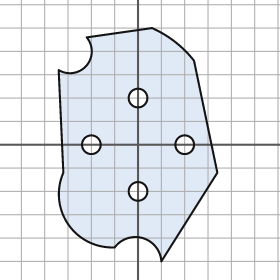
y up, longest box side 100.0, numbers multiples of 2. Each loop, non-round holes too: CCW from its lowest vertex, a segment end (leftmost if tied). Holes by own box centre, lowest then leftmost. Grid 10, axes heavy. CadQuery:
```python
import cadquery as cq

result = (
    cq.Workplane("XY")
    .moveTo(10.0, -50.0)
    .lineTo(34.0, -12.0)
    .lineTo(24.0, 36.0)
    .threePointArc((16.0, 44.0), (6.0, 50.0))
    .lineTo(-22.0, 46.0)
    .threePointArc((-22.0, 34.0), (-34.0, 32.0))
    .lineTo(-32.0, -12.0)
    .threePointArc((-30.0, -34.0), (-10.0, -44.0))
    .threePointArc((2.0, -40.0), (10.0, -50.0))
    .close()
    .moveTo(0.0, -20.0)
    .circle(4.0)
    .moveTo(-20.0, 0.0)
    .circle(4.0)
    .moveTo(20.0, 0.0)
    .circle(4.0)
    .moveTo(0.0, 20.0)
    .circle(4.0)
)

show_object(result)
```